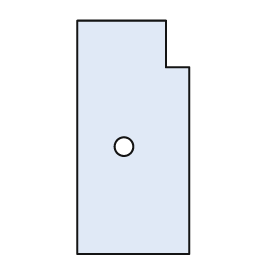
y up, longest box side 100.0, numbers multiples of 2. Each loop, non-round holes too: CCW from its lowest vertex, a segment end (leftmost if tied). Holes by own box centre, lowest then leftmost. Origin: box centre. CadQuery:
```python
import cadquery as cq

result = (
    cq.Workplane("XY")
    .moveTo(-24.0, -50.0)
    .lineTo(24.0, -50.0)
    .lineTo(24.0, 30.0)
    .lineTo(14.0, 30.0)
    .lineTo(14.0, 50.0)
    .lineTo(-24.0, 50.0)
    .close()
    .moveTo(-4.0, -4.0)
    .circle(4.0)
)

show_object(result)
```